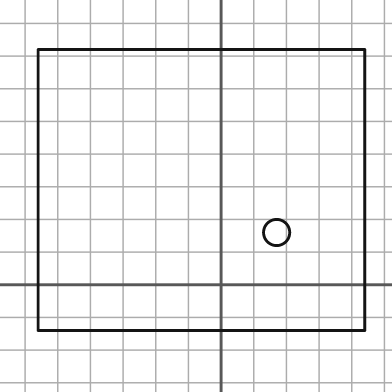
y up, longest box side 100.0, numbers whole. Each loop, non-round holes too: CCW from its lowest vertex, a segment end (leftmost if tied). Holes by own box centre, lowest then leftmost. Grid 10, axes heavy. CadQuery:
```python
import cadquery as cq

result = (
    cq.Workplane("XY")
    .moveTo(-56.0, -14.0)
    .lineTo(44.0, -14.0)
    .lineTo(44.0, 72.0)
    .lineTo(-56.0, 72.0)
    .close()
    .moveTo(17.0, 16.0)
    .circle(4.0)
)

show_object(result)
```